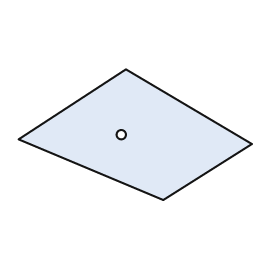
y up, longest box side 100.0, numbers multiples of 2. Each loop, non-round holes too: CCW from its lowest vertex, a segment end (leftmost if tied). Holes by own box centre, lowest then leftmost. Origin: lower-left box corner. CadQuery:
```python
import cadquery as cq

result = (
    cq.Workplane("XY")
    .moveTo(62.0, 0.0)
    .lineTo(100.0, 24.0)
    .lineTo(46.0, 56.0)
    .lineTo(0.0, 26.0)
    .close()
    .moveTo(44.0, 28.0)
    .circle(2.0)
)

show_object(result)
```